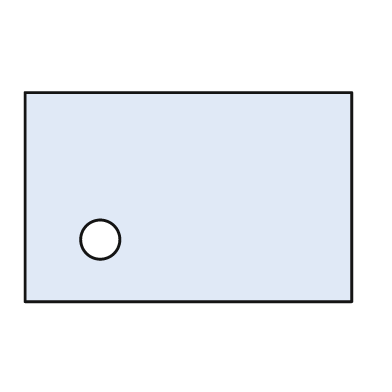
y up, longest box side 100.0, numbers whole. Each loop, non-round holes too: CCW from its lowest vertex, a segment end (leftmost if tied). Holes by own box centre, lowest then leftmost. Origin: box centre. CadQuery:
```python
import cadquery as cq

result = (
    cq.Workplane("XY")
    .moveTo(-50.0, -32.0)
    .lineTo(50.0, -32.0)
    .lineTo(50.0, 32.0)
    .lineTo(-50.0, 32.0)
    .close()
    .moveTo(-27.0, -13.0)
    .circle(6.0)
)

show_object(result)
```